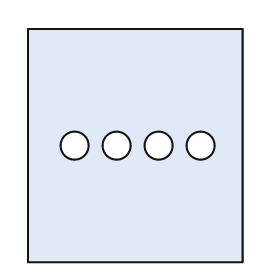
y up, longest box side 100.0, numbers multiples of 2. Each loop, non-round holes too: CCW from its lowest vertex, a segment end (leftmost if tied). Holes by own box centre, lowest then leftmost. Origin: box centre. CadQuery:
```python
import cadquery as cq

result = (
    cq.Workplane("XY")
    .moveTo(-46.0, -50.0)
    .lineTo(46.0, -50.0)
    .lineTo(46.0, 50.0)
    .lineTo(-46.0, 50.0)
    .close()
    .moveTo(-26.0, 0.0)
    .circle(6.0)
    .moveTo(-8.0, 0.0)
    .circle(6.0)
    .moveTo(10.0, 0.0)
    .circle(6.0)
    .moveTo(28.0, 0.0)
    .circle(6.0)
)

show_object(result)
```